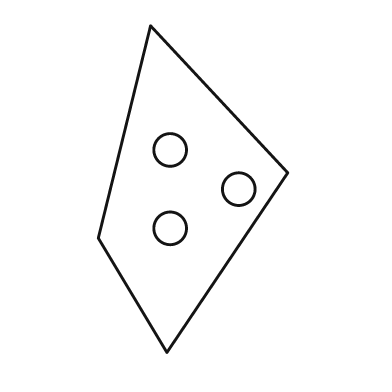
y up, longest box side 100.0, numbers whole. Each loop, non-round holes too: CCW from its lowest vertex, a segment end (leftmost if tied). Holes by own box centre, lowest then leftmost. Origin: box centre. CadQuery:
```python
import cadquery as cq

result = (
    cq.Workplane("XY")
    .moveTo(-8.0, -50.0)
    .lineTo(29.0, 5.0)
    .lineTo(-13.0, 50.0)
    .lineTo(-29.0, -15.0)
    .close()
    .moveTo(-7.0, -12.0)
    .circle(5.0)
    .moveTo(14.0, 0.0)
    .circle(5.0)
    .moveTo(-7.0, 12.0)
    .circle(5.0)
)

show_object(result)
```